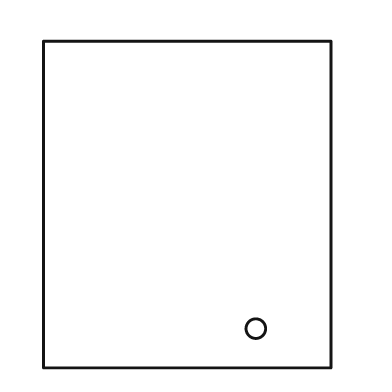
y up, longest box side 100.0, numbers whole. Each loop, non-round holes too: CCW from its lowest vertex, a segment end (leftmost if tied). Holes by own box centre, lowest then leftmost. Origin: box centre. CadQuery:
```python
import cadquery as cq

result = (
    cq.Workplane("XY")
    .moveTo(-44.0, -50.0)
    .lineTo(44.0, -50.0)
    .lineTo(44.0, 50.0)
    .lineTo(-44.0, 50.0)
    .close()
    .moveTo(21.0, -38.0)
    .circle(3.0)
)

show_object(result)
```